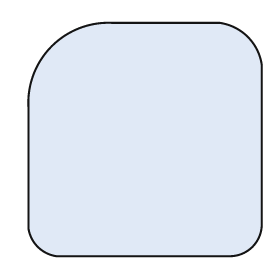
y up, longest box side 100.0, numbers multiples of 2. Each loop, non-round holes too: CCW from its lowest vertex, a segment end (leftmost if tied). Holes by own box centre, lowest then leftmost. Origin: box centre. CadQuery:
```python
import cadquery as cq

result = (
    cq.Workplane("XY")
    .moveTo(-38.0, -50.0)
    .lineTo(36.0, -50.0)
    .threePointArc((46.0, -46.0), (50.0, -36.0))
    .lineTo(50.0, 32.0)
    .threePointArc((44.0, 44.0), (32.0, 50.0))
    .lineTo(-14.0, 50.0)
    .threePointArc((-40.0, 40.0), (-50.0, 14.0))
    .lineTo(-50.0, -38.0)
    .threePointArc((-46.0, -46.0), (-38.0, -50.0))
    .close()
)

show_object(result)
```